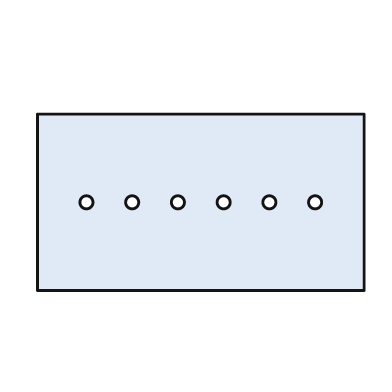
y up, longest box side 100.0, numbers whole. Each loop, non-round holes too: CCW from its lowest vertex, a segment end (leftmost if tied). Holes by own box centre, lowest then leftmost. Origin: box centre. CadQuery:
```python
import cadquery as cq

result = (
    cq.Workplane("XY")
    .moveTo(-50.0, -27.0)
    .lineTo(50.0, -27.0)
    .lineTo(50.0, 27.0)
    .lineTo(-50.0, 27.0)
    .close()
    .moveTo(-35.0, 0.0)
    .circle(2.0)
    .moveTo(-21.0, 0.0)
    .circle(2.0)
    .moveTo(-7.0, 0.0)
    .circle(2.0)
    .moveTo(7.0, 0.0)
    .circle(2.0)
    .moveTo(21.0, 0.0)
    .circle(2.0)
    .moveTo(35.0, 0.0)
    .circle(2.0)
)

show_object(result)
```